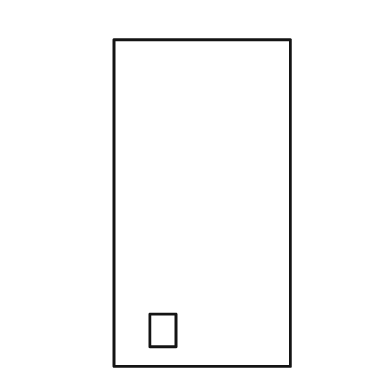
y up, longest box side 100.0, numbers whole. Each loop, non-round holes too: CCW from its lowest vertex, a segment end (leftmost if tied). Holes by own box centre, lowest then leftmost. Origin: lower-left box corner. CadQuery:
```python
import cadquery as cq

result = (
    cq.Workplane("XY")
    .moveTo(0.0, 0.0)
    .lineTo(54.0, 0.0)
    .lineTo(54.0, 100.0)
    .lineTo(0.0, 100.0)
    .close()
    .moveTo(11.0, 6.0)
    .lineTo(19.0, 6.0)
    .lineTo(19.0, 16.0)
    .lineTo(11.0, 16.0)
    .close()
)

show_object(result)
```